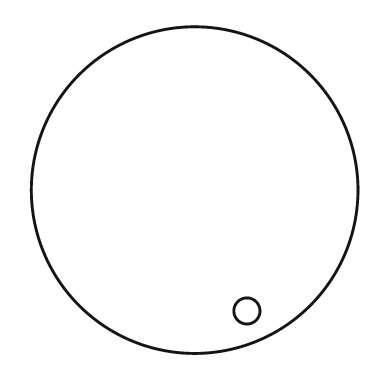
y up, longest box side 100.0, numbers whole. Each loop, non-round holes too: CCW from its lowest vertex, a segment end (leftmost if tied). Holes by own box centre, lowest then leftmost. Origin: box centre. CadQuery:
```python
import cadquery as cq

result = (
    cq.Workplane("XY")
    .moveTo(0.0, 0.0)
    .circle(50.0)
    .moveTo(16.0, -37.0)
    .circle(4.0)
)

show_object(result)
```